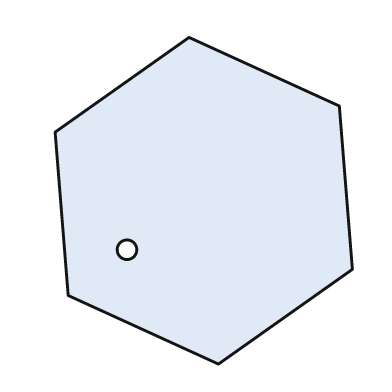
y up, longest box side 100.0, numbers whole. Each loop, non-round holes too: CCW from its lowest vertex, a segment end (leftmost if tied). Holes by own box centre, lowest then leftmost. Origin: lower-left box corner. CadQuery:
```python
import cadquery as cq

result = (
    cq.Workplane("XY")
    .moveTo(50.0, 0.0)
    .lineTo(91.0, 29.0)
    .lineTo(87.0, 79.0)
    .lineTo(41.0, 100.0)
    .lineTo(0.0, 71.0)
    .lineTo(4.0, 21.0)
    .close()
    .moveTo(22.0, 35.0)
    .circle(3.0)
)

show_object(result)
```